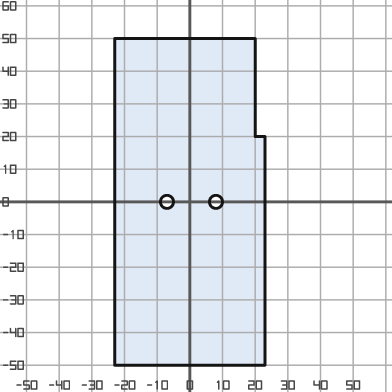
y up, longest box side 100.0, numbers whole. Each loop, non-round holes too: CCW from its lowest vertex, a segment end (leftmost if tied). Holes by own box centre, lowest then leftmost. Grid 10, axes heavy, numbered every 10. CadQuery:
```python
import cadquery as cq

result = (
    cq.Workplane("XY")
    .moveTo(-23.0, -50.0)
    .lineTo(23.0, -50.0)
    .lineTo(23.0, 20.0)
    .lineTo(20.0, 20.0)
    .lineTo(20.0, 50.0)
    .lineTo(-23.0, 50.0)
    .close()
    .moveTo(-7.0, 0.0)
    .circle(2.0)
    .moveTo(8.0, 0.0)
    .circle(2.0)
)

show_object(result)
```